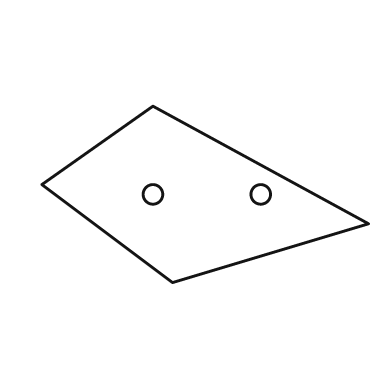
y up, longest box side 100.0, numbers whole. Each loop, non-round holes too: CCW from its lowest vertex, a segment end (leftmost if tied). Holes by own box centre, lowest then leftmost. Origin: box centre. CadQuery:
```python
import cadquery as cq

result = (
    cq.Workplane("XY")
    .moveTo(-10.0, -27.0)
    .lineTo(50.0, -9.0)
    .lineTo(-16.0, 27.0)
    .lineTo(-50.0, 3.0)
    .close()
    .moveTo(-16.0, 0.0)
    .circle(3.0)
    .moveTo(17.0, 0.0)
    .circle(3.0)
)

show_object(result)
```